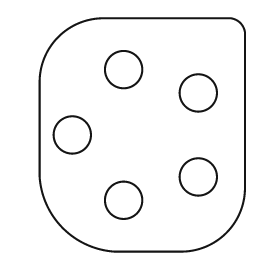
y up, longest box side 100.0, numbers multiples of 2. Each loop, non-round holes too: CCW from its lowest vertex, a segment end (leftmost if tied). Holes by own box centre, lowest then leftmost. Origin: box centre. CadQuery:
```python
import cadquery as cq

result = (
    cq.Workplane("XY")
    .moveTo(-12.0, -50.0)
    .lineTo(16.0, -50.0)
    .threePointArc((36.0, -42.0), (44.0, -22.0))
    .lineTo(44.0, 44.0)
    .threePointArc((42.0, 48.0), (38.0, 50.0))
    .lineTo(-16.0, 50.0)
    .threePointArc((-36.0, 42.0), (-44.0, 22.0))
    .lineTo(-44.0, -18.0)
    .threePointArc((-34.0, -40.0), (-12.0, -50.0))
    .close()
    .moveTo(-8.0, -28.0)
    .circle(8.0)
    .moveTo(24.0, -18.0)
    .circle(8.0)
    .moveTo(-30.0, 0.0)
    .circle(8.0)
    .moveTo(24.0, 18.0)
    .circle(8.0)
    .moveTo(-8.0, 28.0)
    .circle(8.0)
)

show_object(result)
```